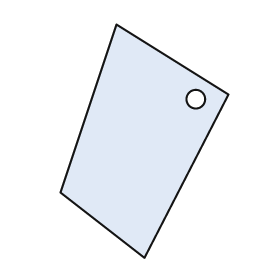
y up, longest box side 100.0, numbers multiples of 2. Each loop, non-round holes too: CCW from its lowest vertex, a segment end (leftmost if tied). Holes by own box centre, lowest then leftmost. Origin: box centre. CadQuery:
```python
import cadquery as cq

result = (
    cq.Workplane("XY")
    .moveTo(0.0, -50.0)
    .lineTo(36.0, 20.0)
    .lineTo(-12.0, 50.0)
    .lineTo(-36.0, -22.0)
    .close()
    .moveTo(22.0, 18.0)
    .circle(4.0)
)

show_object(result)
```